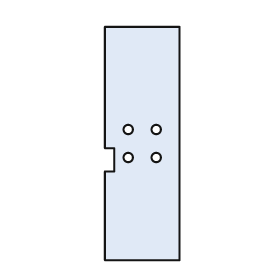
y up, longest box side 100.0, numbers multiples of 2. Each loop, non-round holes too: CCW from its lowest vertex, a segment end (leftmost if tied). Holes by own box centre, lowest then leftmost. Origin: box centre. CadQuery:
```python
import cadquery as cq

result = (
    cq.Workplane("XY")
    .moveTo(-16.0, -50.0)
    .lineTo(16.0, -50.0)
    .lineTo(16.0, 50.0)
    .lineTo(-16.0, 50.0)
    .lineTo(-16.0, -2.0)
    .lineTo(-12.0, -2.0)
    .lineTo(-12.0, -12.0)
    .lineTo(-16.0, -12.0)
    .close()
    .moveTo(-6.0, -6.0)
    .circle(2.0)
    .moveTo(6.0, -6.0)
    .circle(2.0)
    .moveTo(-6.0, 6.0)
    .circle(2.0)
    .moveTo(6.0, 6.0)
    .circle(2.0)
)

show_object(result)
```